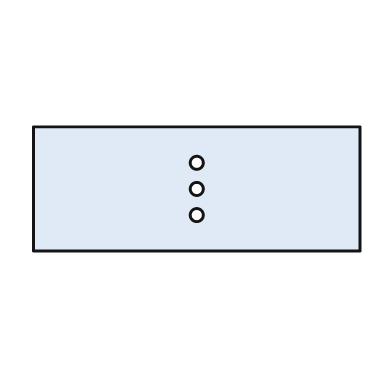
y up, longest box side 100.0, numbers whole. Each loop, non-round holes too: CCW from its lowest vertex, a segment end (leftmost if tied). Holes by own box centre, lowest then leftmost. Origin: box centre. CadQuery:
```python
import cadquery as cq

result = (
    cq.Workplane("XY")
    .moveTo(-50.0, -19.0)
    .lineTo(50.0, -19.0)
    .lineTo(50.0, 19.0)
    .lineTo(-50.0, 19.0)
    .close()
    .moveTo(0.0, -8.0)
    .circle(2.0)
    .moveTo(0.0, 0.0)
    .circle(2.0)
    .moveTo(0.0, 8.0)
    .circle(2.0)
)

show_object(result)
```